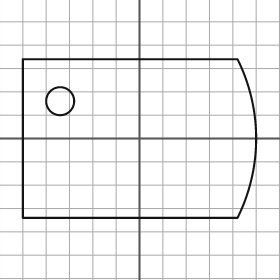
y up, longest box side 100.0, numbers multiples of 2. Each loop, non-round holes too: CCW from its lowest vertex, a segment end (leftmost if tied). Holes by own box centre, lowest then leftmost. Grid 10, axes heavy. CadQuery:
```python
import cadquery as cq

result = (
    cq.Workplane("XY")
    .moveTo(-50.0, -34.0)
    .lineTo(42.0, -34.0)
    .threePointArc((50.0, 0.0), (42.0, 34.0))
    .lineTo(-50.0, 34.0)
    .close()
    .moveTo(-34.0, 16.0)
    .circle(6.0)
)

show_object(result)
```